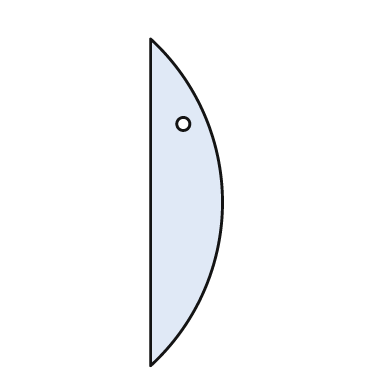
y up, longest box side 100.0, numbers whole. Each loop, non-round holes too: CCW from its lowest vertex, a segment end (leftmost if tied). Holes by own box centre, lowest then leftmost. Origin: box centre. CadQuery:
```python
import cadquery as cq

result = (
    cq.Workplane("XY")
    .moveTo(-11.0, -50.0)
    .threePointArc((11.0, 0.0), (-11.0, 50.0))
    .close()
    .moveTo(-1.0, 24.0)
    .circle(2.0)
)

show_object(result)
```